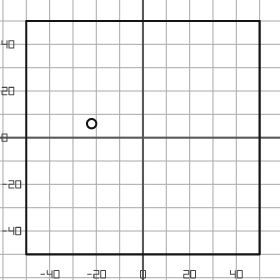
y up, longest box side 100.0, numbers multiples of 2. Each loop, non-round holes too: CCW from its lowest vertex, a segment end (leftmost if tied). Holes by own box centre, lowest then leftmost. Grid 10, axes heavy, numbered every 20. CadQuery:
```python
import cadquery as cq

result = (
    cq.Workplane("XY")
    .moveTo(-50.0, -50.0)
    .lineTo(50.0, -50.0)
    .lineTo(50.0, 50.0)
    .lineTo(-50.0, 50.0)
    .close()
    .moveTo(-22.0, 6.0)
    .circle(2.0)
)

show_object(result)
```